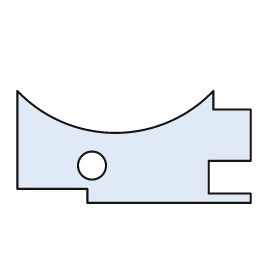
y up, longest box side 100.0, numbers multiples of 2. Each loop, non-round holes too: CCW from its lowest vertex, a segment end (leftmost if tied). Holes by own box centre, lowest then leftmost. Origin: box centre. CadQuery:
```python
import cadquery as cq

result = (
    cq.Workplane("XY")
    .moveTo(-20.0, -24.0)
    .lineTo(50.0, -24.0)
    .lineTo(50.0, -20.0)
    .lineTo(32.0, -20.0)
    .lineTo(32.0, -6.0)
    .lineTo(50.0, -6.0)
    .lineTo(50.0, 16.0)
    .lineTo(34.0, 16.0)
    .lineTo(34.0, 24.0)
    .threePointArc((-8.0, 6.0), (-50.0, 24.0))
    .lineTo(-50.0, -18.0)
    .lineTo(-20.0, -18.0)
    .close()
    .moveTo(-18.0, -8.0)
    .circle(6.0)
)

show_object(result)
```